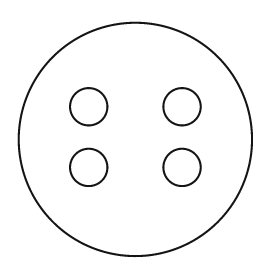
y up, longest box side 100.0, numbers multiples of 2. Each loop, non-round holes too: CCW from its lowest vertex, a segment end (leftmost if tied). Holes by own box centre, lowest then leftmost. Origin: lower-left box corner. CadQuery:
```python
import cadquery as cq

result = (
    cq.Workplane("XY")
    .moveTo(50.0, 50.0)
    .circle(50.0)
    .moveTo(30.0, 38.0)
    .circle(8.0)
    .moveTo(70.0, 38.0)
    .circle(8.0)
    .moveTo(30.0, 64.0)
    .circle(8.0)
    .moveTo(70.0, 64.0)
    .circle(8.0)
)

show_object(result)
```